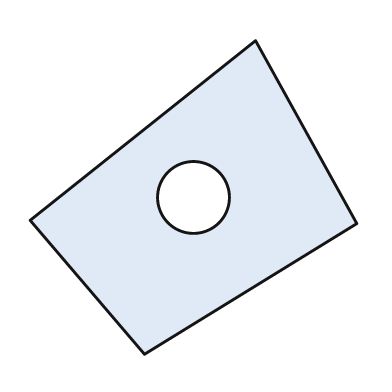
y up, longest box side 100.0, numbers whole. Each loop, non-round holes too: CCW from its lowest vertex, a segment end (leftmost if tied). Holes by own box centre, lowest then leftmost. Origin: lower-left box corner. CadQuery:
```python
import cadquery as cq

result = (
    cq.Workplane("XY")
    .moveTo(35.0, 0.0)
    .lineTo(100.0, 40.0)
    .lineTo(69.0, 96.0)
    .lineTo(0.0, 41.0)
    .close()
    .moveTo(50.0, 48.0)
    .circle(11.0)
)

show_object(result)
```